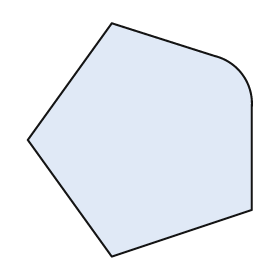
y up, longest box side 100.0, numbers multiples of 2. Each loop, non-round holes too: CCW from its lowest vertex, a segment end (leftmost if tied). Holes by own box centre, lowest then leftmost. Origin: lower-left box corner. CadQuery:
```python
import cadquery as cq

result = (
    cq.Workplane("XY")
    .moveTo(36.0, 0.0)
    .lineTo(96.0, 20.0)
    .lineTo(96.0, 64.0)
    .threePointArc((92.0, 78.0), (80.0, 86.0))
    .lineTo(36.0, 100.0)
    .lineTo(0.0, 50.0)
    .close()
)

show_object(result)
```